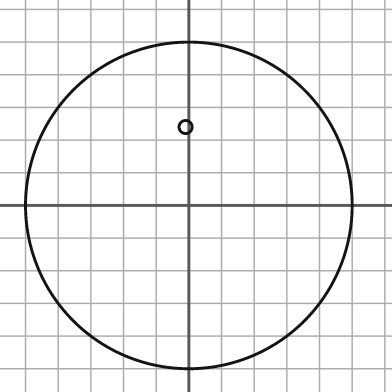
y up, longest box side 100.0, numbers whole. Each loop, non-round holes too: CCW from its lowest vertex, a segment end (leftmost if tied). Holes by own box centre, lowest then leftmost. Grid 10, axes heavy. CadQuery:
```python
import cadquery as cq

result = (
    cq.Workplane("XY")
    .moveTo(0.0, 0.0)
    .circle(50.0)
    .moveTo(-1.0, 24.0)
    .circle(2.0)
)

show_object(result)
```